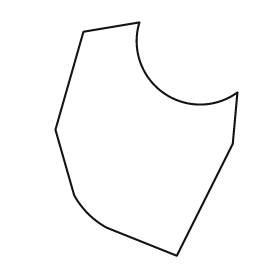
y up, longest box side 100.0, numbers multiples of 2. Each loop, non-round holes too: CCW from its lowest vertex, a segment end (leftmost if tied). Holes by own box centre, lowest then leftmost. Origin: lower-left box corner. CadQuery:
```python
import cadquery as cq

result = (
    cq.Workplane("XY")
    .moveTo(52.0, 0.0)
    .lineTo(76.0, 48.0)
    .lineTo(78.0, 70.0)
    .threePointArc((46.0, 70.0), (36.0, 100.0))
    .lineTo(12.0, 96.0)
    .lineTo(0.0, 54.0)
    .lineTo(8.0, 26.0)
    .threePointArc((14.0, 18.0), (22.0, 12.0))
    .close()
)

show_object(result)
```